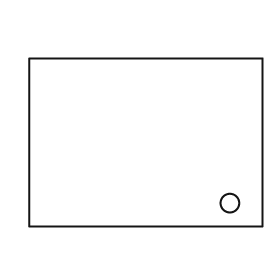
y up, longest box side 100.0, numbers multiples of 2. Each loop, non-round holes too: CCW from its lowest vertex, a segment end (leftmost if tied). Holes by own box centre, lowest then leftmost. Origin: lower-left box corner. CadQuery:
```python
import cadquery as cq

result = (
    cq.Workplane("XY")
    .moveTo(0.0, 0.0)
    .lineTo(100.0, 0.0)
    .lineTo(100.0, 72.0)
    .lineTo(0.0, 72.0)
    .close()
    .moveTo(86.0, 10.0)
    .circle(4.0)
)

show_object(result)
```